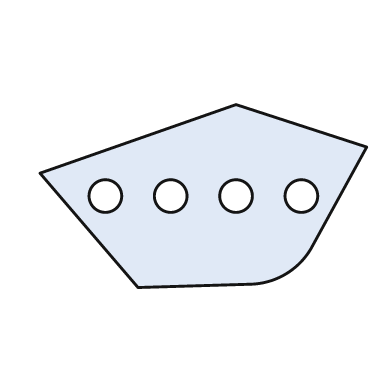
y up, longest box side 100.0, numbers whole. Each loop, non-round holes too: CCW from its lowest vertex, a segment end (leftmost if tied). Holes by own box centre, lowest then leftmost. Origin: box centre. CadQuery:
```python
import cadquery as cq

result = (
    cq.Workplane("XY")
    .moveTo(-20.0, -28.0)
    .lineTo(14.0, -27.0)
    .threePointArc((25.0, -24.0), (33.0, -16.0))
    .lineTo(50.0, 15.0)
    .lineTo(10.0, 28.0)
    .lineTo(-50.0, 7.0)
    .close()
    .moveTo(-30.0, 0.0)
    .circle(5.0)
    .moveTo(-10.0, 0.0)
    .circle(5.0)
    .moveTo(10.0, 0.0)
    .circle(5.0)
    .moveTo(30.0, 0.0)
    .circle(5.0)
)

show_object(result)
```